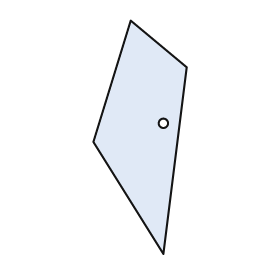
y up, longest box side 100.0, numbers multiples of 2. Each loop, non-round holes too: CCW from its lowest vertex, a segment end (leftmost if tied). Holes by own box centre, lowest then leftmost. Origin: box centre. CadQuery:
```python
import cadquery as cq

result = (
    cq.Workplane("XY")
    .moveTo(10.0, -50.0)
    .lineTo(20.0, 30.0)
    .lineTo(-4.0, 50.0)
    .lineTo(-20.0, -2.0)
    .close()
    .moveTo(10.0, 6.0)
    .circle(2.0)
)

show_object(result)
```